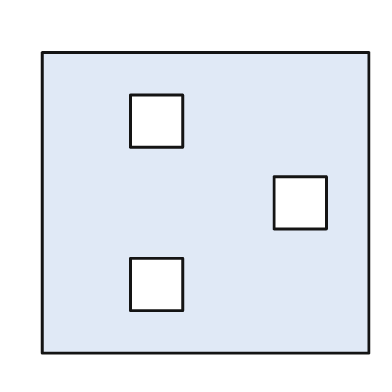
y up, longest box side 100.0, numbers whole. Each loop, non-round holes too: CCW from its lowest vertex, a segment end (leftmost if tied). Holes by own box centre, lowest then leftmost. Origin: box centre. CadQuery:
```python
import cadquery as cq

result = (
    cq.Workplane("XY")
    .moveTo(-50.0, -46.0)
    .lineTo(50.0, -46.0)
    .lineTo(50.0, 46.0)
    .lineTo(-50.0, 46.0)
    .close()
    .moveTo(-23.0, -33.0)
    .lineTo(-7.0, -33.0)
    .lineTo(-7.0, -17.0)
    .lineTo(-23.0, -17.0)
    .close()
    .moveTo(21.0, -8.0)
    .lineTo(37.0, -8.0)
    .lineTo(37.0, 8.0)
    .lineTo(21.0, 8.0)
    .close()
    .moveTo(-23.0, 17.0)
    .lineTo(-7.0, 17.0)
    .lineTo(-7.0, 33.0)
    .lineTo(-23.0, 33.0)
    .close()
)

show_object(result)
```